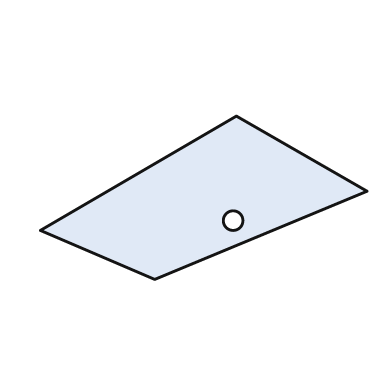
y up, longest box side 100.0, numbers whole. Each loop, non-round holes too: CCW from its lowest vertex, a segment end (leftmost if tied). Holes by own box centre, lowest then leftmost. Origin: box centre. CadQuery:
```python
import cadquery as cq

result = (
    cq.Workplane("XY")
    .moveTo(-15.0, -25.0)
    .lineTo(50.0, 2.0)
    .lineTo(10.0, 25.0)
    .lineTo(-50.0, -10.0)
    .close()
    .moveTo(9.0, -7.0)
    .circle(3.0)
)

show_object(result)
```